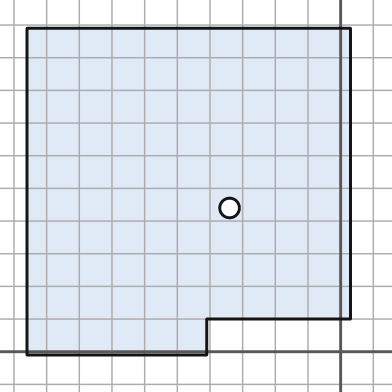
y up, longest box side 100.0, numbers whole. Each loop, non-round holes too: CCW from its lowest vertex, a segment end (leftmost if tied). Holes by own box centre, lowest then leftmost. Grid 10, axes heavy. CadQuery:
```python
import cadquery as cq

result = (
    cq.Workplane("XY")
    .moveTo(-96.0, -1.0)
    .lineTo(-41.0, -1.0)
    .lineTo(-41.0, 10.0)
    .lineTo(3.0, 10.0)
    .lineTo(3.0, 99.0)
    .lineTo(-96.0, 99.0)
    .close()
    .moveTo(-34.0, 44.0)
    .circle(3.0)
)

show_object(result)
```